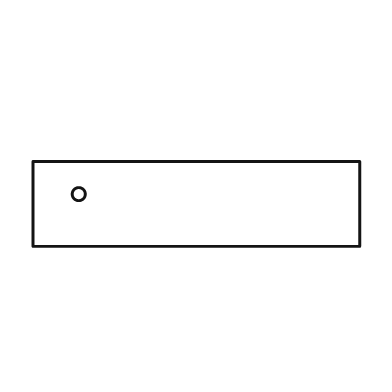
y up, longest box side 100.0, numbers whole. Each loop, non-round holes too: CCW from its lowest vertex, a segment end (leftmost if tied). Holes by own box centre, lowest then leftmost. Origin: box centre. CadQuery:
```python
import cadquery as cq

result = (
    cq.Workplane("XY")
    .moveTo(-50.0, -13.0)
    .lineTo(50.0, -13.0)
    .lineTo(50.0, 13.0)
    .lineTo(-50.0, 13.0)
    .close()
    .moveTo(-36.0, 3.0)
    .circle(2.0)
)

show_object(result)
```